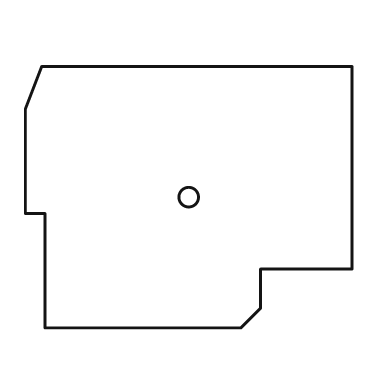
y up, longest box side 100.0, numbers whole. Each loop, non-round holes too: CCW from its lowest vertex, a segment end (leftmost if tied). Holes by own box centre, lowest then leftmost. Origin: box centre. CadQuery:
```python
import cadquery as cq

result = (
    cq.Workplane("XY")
    .moveTo(-44.0, -40.0)
    .lineTo(16.0, -40.0)
    .lineTo(22.0, -34.0)
    .lineTo(22.0, -22.0)
    .lineTo(50.0, -22.0)
    .lineTo(50.0, 40.0)
    .lineTo(-45.0, 40.0)
    .lineTo(-50.0, 27.0)
    .lineTo(-50.0, -5.0)
    .lineTo(-44.0, -5.0)
    .close()
    .moveTo(0.0, 0.0)
    .circle(3.0)
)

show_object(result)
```